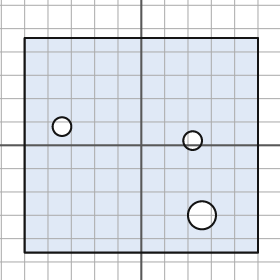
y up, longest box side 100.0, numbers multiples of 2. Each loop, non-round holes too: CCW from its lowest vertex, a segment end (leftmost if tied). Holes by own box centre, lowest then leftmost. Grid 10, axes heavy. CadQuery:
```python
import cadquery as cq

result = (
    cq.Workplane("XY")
    .moveTo(-50.0, -46.0)
    .lineTo(50.0, -46.0)
    .lineTo(50.0, 46.0)
    .lineTo(-50.0, 46.0)
    .close()
    .moveTo(26.0, -30.0)
    .circle(6.0)
    .moveTo(22.0, 2.0)
    .circle(4.0)
    .moveTo(-34.0, 8.0)
    .circle(4.0)
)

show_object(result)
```